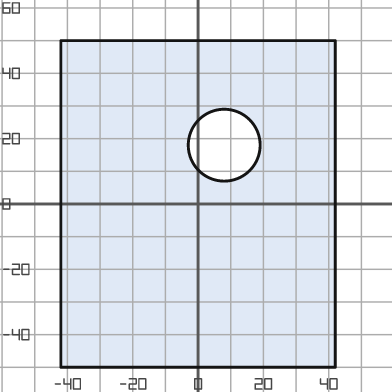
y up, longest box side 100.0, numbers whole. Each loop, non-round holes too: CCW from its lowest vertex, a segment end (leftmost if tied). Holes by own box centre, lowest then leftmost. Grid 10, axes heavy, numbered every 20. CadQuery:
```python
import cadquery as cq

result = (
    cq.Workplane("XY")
    .moveTo(-42.0, -50.0)
    .lineTo(42.0, -50.0)
    .lineTo(42.0, 50.0)
    .lineTo(-42.0, 50.0)
    .close()
    .moveTo(8.0, 18.0)
    .circle(11.0)
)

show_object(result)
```